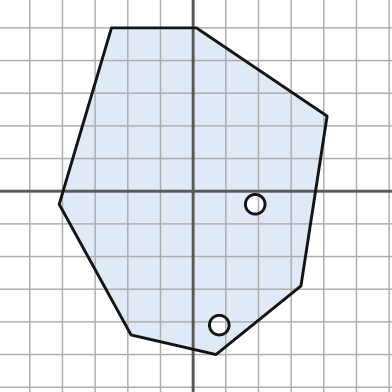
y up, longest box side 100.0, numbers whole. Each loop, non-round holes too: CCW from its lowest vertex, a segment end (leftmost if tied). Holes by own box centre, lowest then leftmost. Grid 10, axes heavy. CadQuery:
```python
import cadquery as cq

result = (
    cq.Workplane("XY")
    .moveTo(7.0, -50.0)
    .lineTo(33.0, -29.0)
    .lineTo(41.0, 23.0)
    .lineTo(1.0, 50.0)
    .lineTo(-25.0, 50.0)
    .lineTo(-41.0, -4.0)
    .lineTo(-19.0, -44.0)
    .close()
    .moveTo(8.0, -41.0)
    .circle(3.0)
    .moveTo(19.0, -4.0)
    .circle(3.0)
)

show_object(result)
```